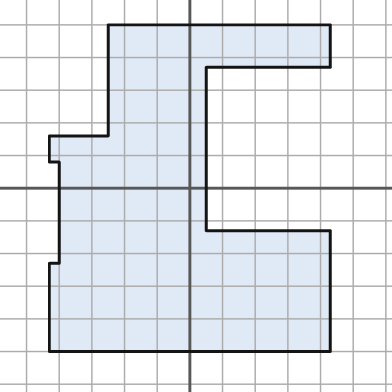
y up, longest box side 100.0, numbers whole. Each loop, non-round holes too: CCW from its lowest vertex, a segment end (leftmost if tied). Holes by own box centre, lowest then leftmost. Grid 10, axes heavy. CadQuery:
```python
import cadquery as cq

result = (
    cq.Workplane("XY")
    .moveTo(-43.0, -50.0)
    .lineTo(43.0, -50.0)
    .lineTo(43.0, -13.0)
    .lineTo(5.0, -13.0)
    .lineTo(5.0, 37.0)
    .lineTo(43.0, 37.0)
    .lineTo(43.0, 50.0)
    .lineTo(-25.0, 50.0)
    .lineTo(-25.0, 16.0)
    .lineTo(-43.0, 16.0)
    .lineTo(-43.0, 8.0)
    .lineTo(-40.0, 8.0)
    .lineTo(-40.0, -23.0)
    .lineTo(-43.0, -23.0)
    .close()
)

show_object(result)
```